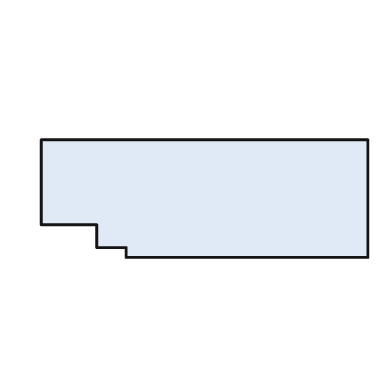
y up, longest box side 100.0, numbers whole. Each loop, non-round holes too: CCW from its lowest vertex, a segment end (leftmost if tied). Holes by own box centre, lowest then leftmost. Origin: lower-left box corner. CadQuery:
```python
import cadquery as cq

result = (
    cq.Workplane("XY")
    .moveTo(26.0, 0.0)
    .lineTo(100.0, 0.0)
    .lineTo(100.0, 36.0)
    .lineTo(0.0, 36.0)
    .lineTo(0.0, 10.0)
    .lineTo(17.0, 10.0)
    .lineTo(17.0, 3.0)
    .lineTo(26.0, 3.0)
    .close()
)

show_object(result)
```